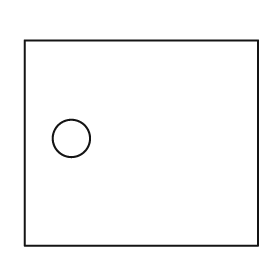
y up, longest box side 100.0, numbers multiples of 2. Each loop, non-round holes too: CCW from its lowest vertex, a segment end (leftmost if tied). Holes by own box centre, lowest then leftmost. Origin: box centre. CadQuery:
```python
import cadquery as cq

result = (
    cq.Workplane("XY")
    .moveTo(-50.0, -44.0)
    .lineTo(50.0, -44.0)
    .lineTo(50.0, 44.0)
    .lineTo(-50.0, 44.0)
    .close()
    .moveTo(-30.0, 2.0)
    .circle(8.0)
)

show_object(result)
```